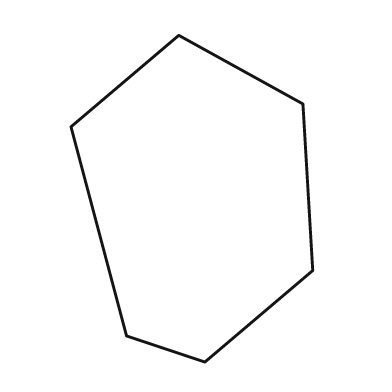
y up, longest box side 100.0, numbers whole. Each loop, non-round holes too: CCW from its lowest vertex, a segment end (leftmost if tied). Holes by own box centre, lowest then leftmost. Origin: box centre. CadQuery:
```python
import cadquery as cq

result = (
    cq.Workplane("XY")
    .moveTo(4.0, -50.0)
    .lineTo(37.0, -22.0)
    .lineTo(34.0, 29.0)
    .lineTo(-4.0, 50.0)
    .lineTo(-37.0, 22.0)
    .lineTo(-20.0, -42.0)
    .close()
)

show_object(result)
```